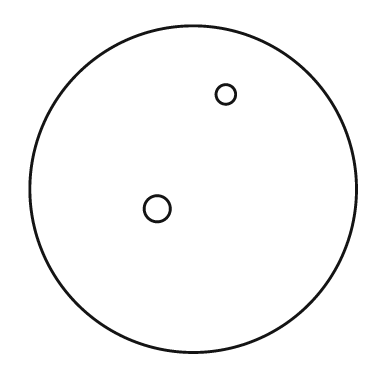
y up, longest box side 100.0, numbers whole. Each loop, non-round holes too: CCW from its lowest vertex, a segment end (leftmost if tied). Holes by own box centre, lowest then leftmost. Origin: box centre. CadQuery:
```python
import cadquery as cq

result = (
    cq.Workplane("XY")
    .moveTo(0.0, 0.0)
    .circle(50.0)
    .moveTo(-11.0, -6.0)
    .circle(4.0)
    .moveTo(10.0, 29.0)
    .circle(3.0)
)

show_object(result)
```